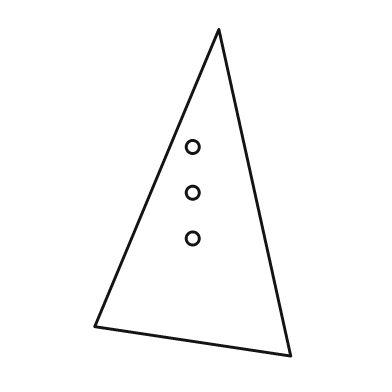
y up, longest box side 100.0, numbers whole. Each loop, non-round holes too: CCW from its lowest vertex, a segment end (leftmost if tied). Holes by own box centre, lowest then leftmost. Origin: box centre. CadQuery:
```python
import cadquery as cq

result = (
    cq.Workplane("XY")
    .moveTo(30.0, -50.0)
    .lineTo(8.0, 50.0)
    .lineTo(-30.0, -41.0)
    .close()
    .moveTo(0.0, -14.0)
    .circle(2.0)
    .moveTo(0.0, 0.0)
    .circle(2.0)
    .moveTo(0.0, 14.0)
    .circle(2.0)
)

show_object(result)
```